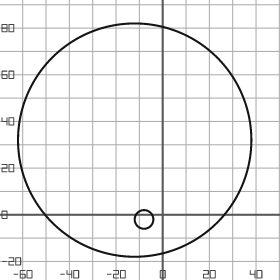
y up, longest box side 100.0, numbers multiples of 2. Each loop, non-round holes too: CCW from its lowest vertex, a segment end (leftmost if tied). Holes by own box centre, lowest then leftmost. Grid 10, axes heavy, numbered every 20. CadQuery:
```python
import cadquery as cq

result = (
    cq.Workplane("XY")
    .moveTo(-12.0, 32.0)
    .circle(50.0)
    .moveTo(-8.0, -2.0)
    .circle(4.0)
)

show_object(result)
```